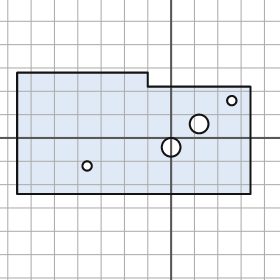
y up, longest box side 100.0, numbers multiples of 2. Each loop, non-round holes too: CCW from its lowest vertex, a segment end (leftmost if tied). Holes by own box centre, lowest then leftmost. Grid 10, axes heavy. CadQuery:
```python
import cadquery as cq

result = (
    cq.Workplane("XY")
    .moveTo(-66.0, -24.0)
    .lineTo(34.0, -24.0)
    .lineTo(34.0, 22.0)
    .lineTo(-10.0, 22.0)
    .lineTo(-10.0, 28.0)
    .lineTo(-66.0, 28.0)
    .close()
    .moveTo(-36.0, -12.0)
    .circle(2.0)
    .moveTo(0.0, -4.0)
    .circle(4.0)
    .moveTo(12.0, 6.0)
    .circle(4.0)
    .moveTo(26.0, 16.0)
    .circle(2.0)
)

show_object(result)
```